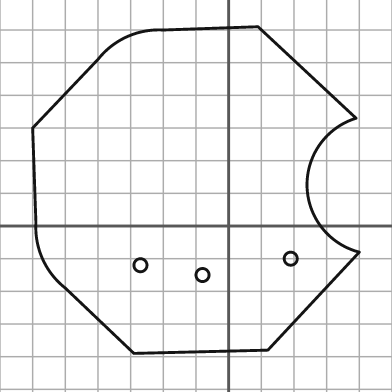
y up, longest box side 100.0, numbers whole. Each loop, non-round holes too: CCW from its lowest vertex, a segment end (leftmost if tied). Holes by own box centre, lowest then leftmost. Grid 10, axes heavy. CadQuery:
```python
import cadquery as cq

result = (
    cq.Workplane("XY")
    .moveTo(-29.0, -39.0)
    .lineTo(12.0, -38.0)
    .lineTo(40.0, -8.0)
    .threePointArc((24.0, 12.0), (39.0, 33.0))
    .lineTo(9.0, 61.0)
    .lineTo(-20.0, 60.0)
    .threePointArc((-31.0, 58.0), (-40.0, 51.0))
    .lineTo(-60.0, 30.0)
    .lineTo(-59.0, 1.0)
    .threePointArc((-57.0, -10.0), (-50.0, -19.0))
    .close()
    .moveTo(-8.0, -15.0)
    .circle(2.0)
    .moveTo(-27.0, -12.0)
    .circle(2.0)
    .moveTo(19.0, -10.0)
    .circle(2.0)
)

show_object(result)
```